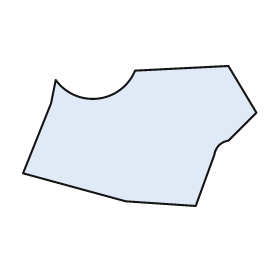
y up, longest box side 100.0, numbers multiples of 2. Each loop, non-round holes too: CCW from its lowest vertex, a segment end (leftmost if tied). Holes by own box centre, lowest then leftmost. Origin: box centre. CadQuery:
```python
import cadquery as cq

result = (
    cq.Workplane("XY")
    .moveTo(24.0, -30.0)
    .lineTo(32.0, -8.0)
    .threePointArc((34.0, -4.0), (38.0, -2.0))
    .lineTo(50.0, 10.0)
    .lineTo(38.0, 30.0)
    .lineTo(-2.0, 28.0)
    .threePointArc((-18.0, 16.0), (-36.0, 24.0))
    .lineTo(-38.0, 14.0)
    .lineTo(-50.0, -16.0)
    .lineTo(-6.0, -28.0)
    .close()
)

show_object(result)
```